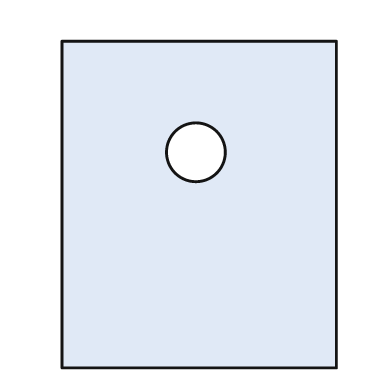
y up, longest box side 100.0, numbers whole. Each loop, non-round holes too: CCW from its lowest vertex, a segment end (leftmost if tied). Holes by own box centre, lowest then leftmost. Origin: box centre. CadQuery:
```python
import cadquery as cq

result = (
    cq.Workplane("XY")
    .moveTo(-42.0, -50.0)
    .lineTo(42.0, -50.0)
    .lineTo(42.0, 50.0)
    .lineTo(-42.0, 50.0)
    .close()
    .moveTo(-1.0, 16.0)
    .circle(9.0)
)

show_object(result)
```